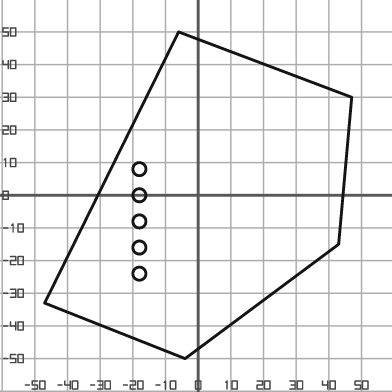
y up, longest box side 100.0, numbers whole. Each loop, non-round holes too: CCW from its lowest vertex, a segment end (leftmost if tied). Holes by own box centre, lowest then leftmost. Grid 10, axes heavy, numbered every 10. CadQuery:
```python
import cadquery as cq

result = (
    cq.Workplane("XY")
    .moveTo(-4.0, -50.0)
    .lineTo(43.0, -15.0)
    .lineTo(47.0, 30.0)
    .lineTo(-6.0, 50.0)
    .lineTo(-47.0, -33.0)
    .close()
    .moveTo(-18.0, -24.0)
    .circle(2.0)
    .moveTo(-18.0, -16.0)
    .circle(2.0)
    .moveTo(-18.0, -8.0)
    .circle(2.0)
    .moveTo(-18.0, 0.0)
    .circle(2.0)
    .moveTo(-18.0, 8.0)
    .circle(2.0)
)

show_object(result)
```